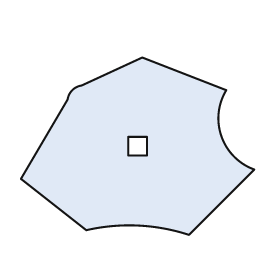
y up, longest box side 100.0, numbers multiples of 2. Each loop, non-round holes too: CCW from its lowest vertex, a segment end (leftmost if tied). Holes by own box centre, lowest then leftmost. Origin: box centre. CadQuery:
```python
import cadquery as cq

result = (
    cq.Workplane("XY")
    .moveTo(22.0, -38.0)
    .lineTo(50.0, -10.0)
    .threePointArc((36.0, 4.0), (38.0, 24.0))
    .lineTo(2.0, 38.0)
    .lineTo(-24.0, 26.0)
    .threePointArc((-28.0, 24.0), (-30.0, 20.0))
    .lineTo(-50.0, -14.0)
    .lineTo(-22.0, -36.0)
    .threePointArc((0.0, -34.0), (22.0, -38.0))
    .close()
    .moveTo(-4.0, -4.0)
    .lineTo(4.0, -4.0)
    .lineTo(4.0, 4.0)
    .lineTo(-4.0, 4.0)
    .close()
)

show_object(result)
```